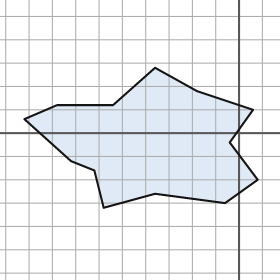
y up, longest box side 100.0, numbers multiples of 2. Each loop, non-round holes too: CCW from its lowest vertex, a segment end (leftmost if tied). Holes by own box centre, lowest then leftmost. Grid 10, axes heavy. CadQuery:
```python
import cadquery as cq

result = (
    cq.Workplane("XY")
    .moveTo(-58.0, -32.0)
    .lineTo(-36.0, -26.0)
    .lineTo(-6.0, -30.0)
    .lineTo(8.0, -20.0)
    .lineTo(-4.0, -4.0)
    .lineTo(6.0, 10.0)
    .lineTo(-18.0, 18.0)
    .lineTo(-36.0, 28.0)
    .lineTo(-54.0, 12.0)
    .lineTo(-78.0, 12.0)
    .lineTo(-92.0, 6.0)
    .lineTo(-72.0, -12.0)
    .lineTo(-62.0, -16.0)
    .close()
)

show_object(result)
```